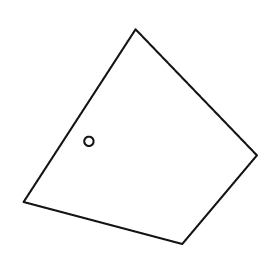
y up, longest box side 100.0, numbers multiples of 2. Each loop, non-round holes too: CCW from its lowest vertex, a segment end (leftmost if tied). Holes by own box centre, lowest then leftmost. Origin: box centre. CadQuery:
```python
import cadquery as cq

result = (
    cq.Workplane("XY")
    .moveTo(18.0, -46.0)
    .lineTo(50.0, -8.0)
    .lineTo(-2.0, 46.0)
    .lineTo(-50.0, -28.0)
    .close()
    .moveTo(-22.0, -2.0)
    .circle(2.0)
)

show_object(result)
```